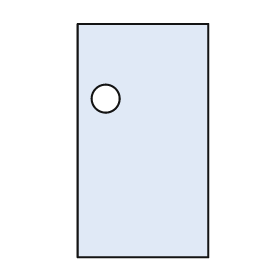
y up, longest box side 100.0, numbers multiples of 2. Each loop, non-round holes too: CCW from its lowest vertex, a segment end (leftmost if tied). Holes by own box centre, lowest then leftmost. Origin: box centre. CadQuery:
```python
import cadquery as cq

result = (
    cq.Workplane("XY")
    .moveTo(-28.0, -50.0)
    .lineTo(28.0, -50.0)
    .lineTo(28.0, 50.0)
    .lineTo(-28.0, 50.0)
    .close()
    .moveTo(-16.0, 18.0)
    .circle(6.0)
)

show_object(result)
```